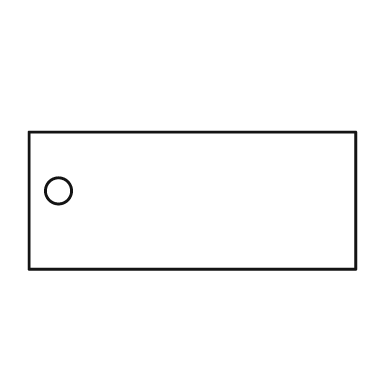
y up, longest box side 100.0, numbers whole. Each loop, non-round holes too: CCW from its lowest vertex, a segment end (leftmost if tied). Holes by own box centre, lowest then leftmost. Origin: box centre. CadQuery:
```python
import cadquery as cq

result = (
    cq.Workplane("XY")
    .moveTo(-50.0, -21.0)
    .lineTo(50.0, -21.0)
    .lineTo(50.0, 21.0)
    .lineTo(-50.0, 21.0)
    .close()
    .moveTo(-41.0, 3.0)
    .circle(4.0)
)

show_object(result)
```